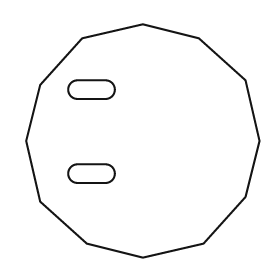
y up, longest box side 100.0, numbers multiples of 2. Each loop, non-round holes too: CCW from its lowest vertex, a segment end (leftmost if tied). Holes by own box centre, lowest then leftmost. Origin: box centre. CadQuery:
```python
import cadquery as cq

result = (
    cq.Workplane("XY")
    .moveTo(0.0, -50.0)
    .lineTo(26.0, -44.0)
    .lineTo(44.0, -24.0)
    .lineTo(50.0, 0.0)
    .lineTo(44.0, 26.0)
    .lineTo(24.0, 44.0)
    .lineTo(0.0, 50.0)
    .lineTo(-26.0, 44.0)
    .lineTo(-44.0, 24.0)
    .lineTo(-50.0, 0.0)
    .lineTo(-44.0, -26.0)
    .lineTo(-24.0, -44.0)
    .close()
    .moveTo(-28.0, -18.0)
    .lineTo(-16.0, -18.0)
    .threePointArc((-12.0, -14.0), (-16.0, -10.0))
    .lineTo(-28.0, -10.0)
    .threePointArc((-32.0, -14.0), (-28.0, -18.0))
    .close()
    .moveTo(-28.0, 18.0)
    .lineTo(-16.0, 18.0)
    .threePointArc((-12.0, 22.0), (-16.0, 26.0))
    .lineTo(-28.0, 26.0)
    .threePointArc((-32.0, 22.0), (-28.0, 18.0))
    .close()
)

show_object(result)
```